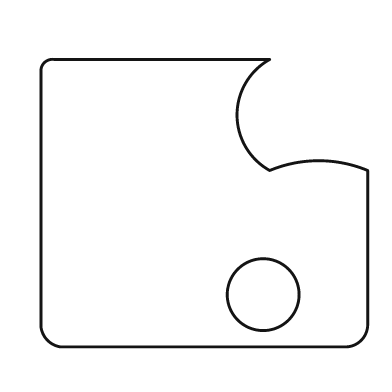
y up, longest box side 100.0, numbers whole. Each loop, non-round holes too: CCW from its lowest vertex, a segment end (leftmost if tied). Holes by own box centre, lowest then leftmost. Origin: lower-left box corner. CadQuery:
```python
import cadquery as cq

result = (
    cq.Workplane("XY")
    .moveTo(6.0, 0.0)
    .lineTo(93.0, 0.0)
    .threePointArc((98.0, 2.0), (100.0, 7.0))
    .lineTo(100.0, 54.0)
    .threePointArc((85.0, 57.0), (70.0, 54.0))
    .threePointArc((60.0, 71.0), (70.0, 88.0))
    .lineTo(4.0, 88.0)
    .threePointArc((1.0, 87.0), (0.0, 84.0))
    .lineTo(0.0, 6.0)
    .threePointArc((2.0, 2.0), (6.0, 0.0))
    .close()
    .moveTo(68.0, 16.0)
    .circle(11.0)
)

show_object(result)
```